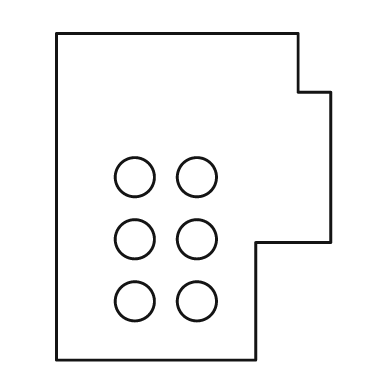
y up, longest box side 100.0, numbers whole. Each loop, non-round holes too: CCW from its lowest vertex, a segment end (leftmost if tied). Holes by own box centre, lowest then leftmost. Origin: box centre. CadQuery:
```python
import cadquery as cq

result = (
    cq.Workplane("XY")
    .moveTo(-42.0, -50.0)
    .lineTo(19.0, -50.0)
    .lineTo(19.0, -14.0)
    .lineTo(42.0, -14.0)
    .lineTo(42.0, 32.0)
    .lineTo(32.0, 32.0)
    .lineTo(32.0, 50.0)
    .lineTo(-42.0, 50.0)
    .close()
    .moveTo(-18.0, -32.0)
    .circle(6.0)
    .moveTo(1.0, -32.0)
    .circle(6.0)
    .moveTo(-18.0, -13.0)
    .circle(6.0)
    .moveTo(1.0, -13.0)
    .circle(6.0)
    .moveTo(-18.0, 6.0)
    .circle(6.0)
    .moveTo(1.0, 6.0)
    .circle(6.0)
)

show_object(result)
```